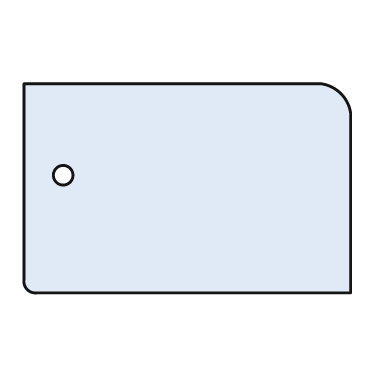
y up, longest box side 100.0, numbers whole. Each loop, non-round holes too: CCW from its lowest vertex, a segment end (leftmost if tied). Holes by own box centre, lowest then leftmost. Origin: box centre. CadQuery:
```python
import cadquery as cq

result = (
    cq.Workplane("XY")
    .moveTo(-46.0, -32.0)
    .lineTo(50.0, -32.0)
    .lineTo(50.0, 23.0)
    .threePointArc((47.0, 29.0), (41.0, 32.0))
    .lineTo(-50.0, 32.0)
    .lineTo(-50.0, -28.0)
    .threePointArc((-49.0, -31.0), (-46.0, -32.0))
    .close()
    .moveTo(-38.0, 4.0)
    .circle(3.0)
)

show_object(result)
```